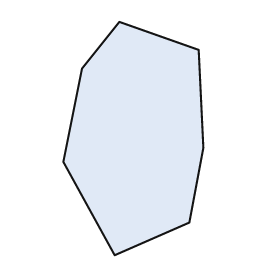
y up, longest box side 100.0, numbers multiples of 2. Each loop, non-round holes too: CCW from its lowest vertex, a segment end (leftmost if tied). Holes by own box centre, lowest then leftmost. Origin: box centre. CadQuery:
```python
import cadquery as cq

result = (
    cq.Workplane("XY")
    .moveTo(-8.0, -50.0)
    .lineTo(24.0, -36.0)
    .lineTo(30.0, -4.0)
    .lineTo(28.0, 38.0)
    .lineTo(-6.0, 50.0)
    .lineTo(-22.0, 30.0)
    .lineTo(-30.0, -10.0)
    .close()
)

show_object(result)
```